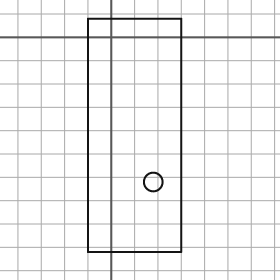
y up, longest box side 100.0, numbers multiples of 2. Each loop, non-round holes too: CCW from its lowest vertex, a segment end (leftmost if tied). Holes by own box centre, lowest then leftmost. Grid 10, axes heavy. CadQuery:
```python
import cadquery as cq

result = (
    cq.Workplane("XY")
    .moveTo(-10.0, -92.0)
    .lineTo(30.0, -92.0)
    .lineTo(30.0, 8.0)
    .lineTo(-10.0, 8.0)
    .close()
    .moveTo(18.0, -62.0)
    .circle(4.0)
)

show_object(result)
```